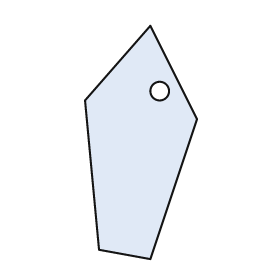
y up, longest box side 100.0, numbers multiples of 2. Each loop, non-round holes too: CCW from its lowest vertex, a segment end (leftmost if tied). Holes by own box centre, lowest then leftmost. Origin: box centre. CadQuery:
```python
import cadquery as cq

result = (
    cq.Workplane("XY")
    .moveTo(4.0, -50.0)
    .lineTo(24.0, 10.0)
    .lineTo(4.0, 50.0)
    .lineTo(-24.0, 18.0)
    .lineTo(-18.0, -46.0)
    .close()
    .moveTo(8.0, 22.0)
    .circle(4.0)
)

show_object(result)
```